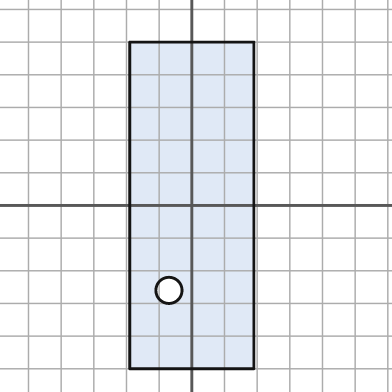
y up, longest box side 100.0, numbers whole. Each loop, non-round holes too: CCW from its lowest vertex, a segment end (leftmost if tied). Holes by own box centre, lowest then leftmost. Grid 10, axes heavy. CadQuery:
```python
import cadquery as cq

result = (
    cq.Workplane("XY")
    .moveTo(-19.0, -50.0)
    .lineTo(19.0, -50.0)
    .lineTo(19.0, 50.0)
    .lineTo(-19.0, 50.0)
    .close()
    .moveTo(-7.0, -26.0)
    .circle(4.0)
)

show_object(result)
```